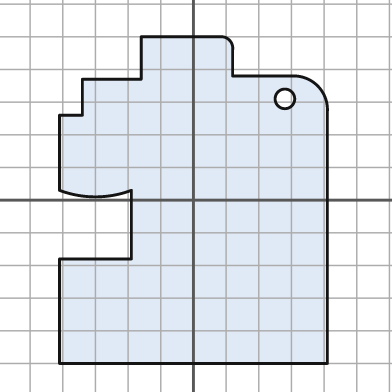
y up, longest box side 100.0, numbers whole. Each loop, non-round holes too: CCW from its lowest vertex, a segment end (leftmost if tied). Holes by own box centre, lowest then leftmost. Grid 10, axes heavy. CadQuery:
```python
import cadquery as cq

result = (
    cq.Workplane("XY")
    .moveTo(-41.0, -50.0)
    .lineTo(41.0, -50.0)
    .lineTo(41.0, 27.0)
    .threePointArc((38.0, 35.0), (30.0, 38.0))
    .lineTo(12.0, 38.0)
    .lineTo(12.0, 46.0)
    .threePointArc((11.0, 49.0), (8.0, 50.0))
    .lineTo(-16.0, 50.0)
    .lineTo(-16.0, 37.0)
    .lineTo(-34.0, 37.0)
    .lineTo(-34.0, 26.0)
    .lineTo(-41.0, 26.0)
    .lineTo(-41.0, 3.0)
    .threePointArc((-30.0, 1.0), (-19.0, 3.0))
    .lineTo(-19.0, -18.0)
    .lineTo(-41.0, -18.0)
    .close()
    .moveTo(28.0, 31.0)
    .circle(3.0)
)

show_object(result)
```